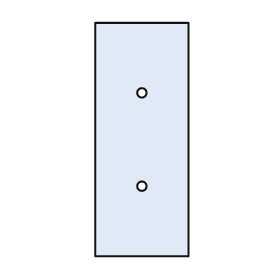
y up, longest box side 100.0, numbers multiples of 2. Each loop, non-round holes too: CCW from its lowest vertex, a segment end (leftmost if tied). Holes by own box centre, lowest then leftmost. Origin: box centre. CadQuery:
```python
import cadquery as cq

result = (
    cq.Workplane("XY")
    .moveTo(-20.0, -50.0)
    .lineTo(20.0, -50.0)
    .lineTo(20.0, 50.0)
    .lineTo(-20.0, 50.0)
    .close()
    .moveTo(0.0, -20.0)
    .circle(2.0)
    .moveTo(0.0, 20.0)
    .circle(2.0)
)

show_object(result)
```